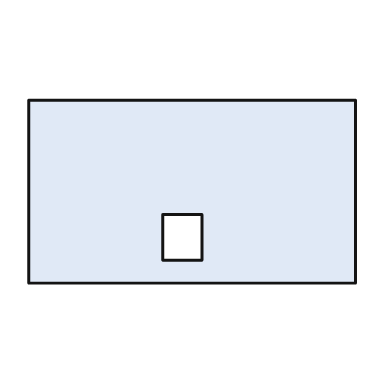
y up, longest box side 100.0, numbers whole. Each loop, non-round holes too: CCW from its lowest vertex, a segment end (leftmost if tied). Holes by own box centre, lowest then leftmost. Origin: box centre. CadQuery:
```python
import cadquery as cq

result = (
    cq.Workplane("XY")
    .moveTo(-50.0, -28.0)
    .lineTo(50.0, -28.0)
    .lineTo(50.0, 28.0)
    .lineTo(-50.0, 28.0)
    .close()
    .moveTo(-9.0, -21.0)
    .lineTo(3.0, -21.0)
    .lineTo(3.0, -7.0)
    .lineTo(-9.0, -7.0)
    .close()
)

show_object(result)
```